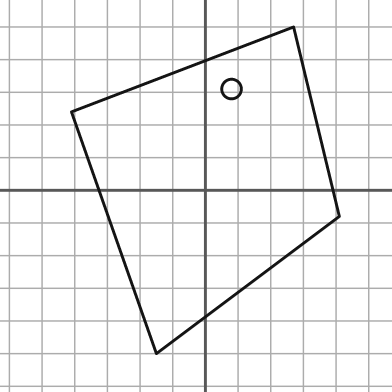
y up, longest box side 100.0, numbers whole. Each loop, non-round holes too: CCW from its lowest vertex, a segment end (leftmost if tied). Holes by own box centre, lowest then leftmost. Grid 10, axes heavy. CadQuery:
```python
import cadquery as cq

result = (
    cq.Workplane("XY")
    .moveTo(-15.0, -50.0)
    .lineTo(41.0, -8.0)
    .lineTo(27.0, 50.0)
    .lineTo(-41.0, 24.0)
    .close()
    .moveTo(8.0, 31.0)
    .circle(3.0)
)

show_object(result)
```